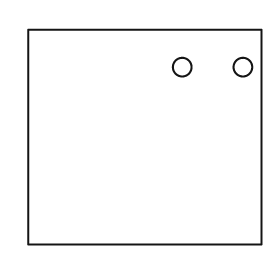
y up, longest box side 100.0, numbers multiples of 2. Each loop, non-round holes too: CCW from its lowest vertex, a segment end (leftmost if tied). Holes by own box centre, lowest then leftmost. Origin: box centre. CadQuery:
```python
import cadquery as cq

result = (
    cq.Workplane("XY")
    .moveTo(-50.0, -46.0)
    .lineTo(50.0, -46.0)
    .lineTo(50.0, 46.0)
    .lineTo(-50.0, 46.0)
    .close()
    .moveTo(16.0, 30.0)
    .circle(4.0)
    .moveTo(42.0, 30.0)
    .circle(4.0)
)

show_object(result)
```